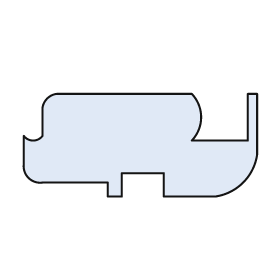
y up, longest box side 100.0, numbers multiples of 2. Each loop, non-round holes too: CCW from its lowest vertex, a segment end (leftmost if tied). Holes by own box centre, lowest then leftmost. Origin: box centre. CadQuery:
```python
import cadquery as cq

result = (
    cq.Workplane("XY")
    .moveTo(-14.0, -22.0)
    .lineTo(-8.0, -22.0)
    .lineTo(-8.0, -12.0)
    .lineTo(10.0, -12.0)
    .lineTo(10.0, -22.0)
    .lineTo(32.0, -22.0)
    .threePointArc((44.0, -16.0), (50.0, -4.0))
    .lineTo(50.0, 22.0)
    .lineTo(46.0, 22.0)
    .lineTo(46.0, 2.0)
    .lineTo(22.0, 2.0)
    .threePointArc((26.0, 12.0), (22.0, 22.0))
    .lineTo(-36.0, 22.0)
    .threePointArc((-40.0, 20.0), (-42.0, 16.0))
    .lineTo(-42.0, 4.0)
    .threePointArc((-46.0, 2.0), (-50.0, 4.0))
    .lineTo(-50.0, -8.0)
    .threePointArc((-48.0, -14.0), (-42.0, -16.0))
    .lineTo(-14.0, -16.0)
    .close()
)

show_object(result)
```